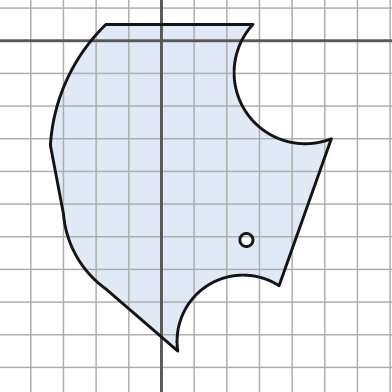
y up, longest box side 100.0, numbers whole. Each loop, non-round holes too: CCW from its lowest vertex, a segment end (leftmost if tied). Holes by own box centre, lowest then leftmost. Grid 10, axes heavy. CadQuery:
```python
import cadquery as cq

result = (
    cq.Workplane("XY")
    .moveTo(5.0, -95.0)
    .threePointArc((14.0, -75.0), (36.0, -75.0))
    .lineTo(52.0, -30.0)
    .threePointArc((26.0, -22.0), (28.0, 5.0))
    .lineTo(-17.0, 5.0)
    .threePointArc((-29.0, -12.0), (-34.0, -32.0))
    .lineTo(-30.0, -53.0)
    .threePointArc((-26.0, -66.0), (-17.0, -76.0))
    .close()
    .moveTo(26.0, -61.0)
    .circle(2.0)
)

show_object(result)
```